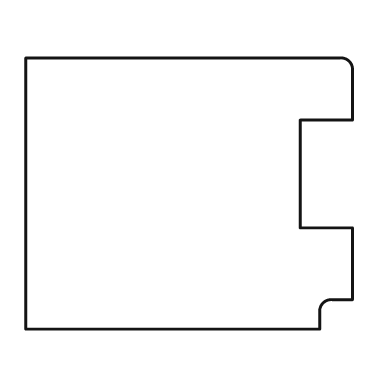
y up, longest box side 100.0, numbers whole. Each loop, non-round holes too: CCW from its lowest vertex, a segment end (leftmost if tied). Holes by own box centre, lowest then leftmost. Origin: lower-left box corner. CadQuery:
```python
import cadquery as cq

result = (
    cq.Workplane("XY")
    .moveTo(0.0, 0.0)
    .lineTo(90.0, 0.0)
    .lineTo(90.0, 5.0)
    .threePointArc((91.0, 8.0), (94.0, 9.0))
    .lineTo(100.0, 9.0)
    .lineTo(100.0, 31.0)
    .lineTo(84.0, 31.0)
    .lineTo(84.0, 64.0)
    .lineTo(100.0, 64.0)
    .lineTo(100.0, 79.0)
    .threePointArc((99.0, 82.0), (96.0, 83.0))
    .lineTo(0.0, 83.0)
    .close()
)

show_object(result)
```